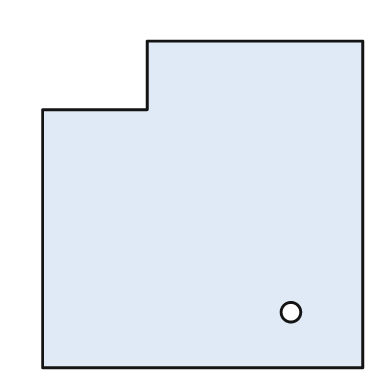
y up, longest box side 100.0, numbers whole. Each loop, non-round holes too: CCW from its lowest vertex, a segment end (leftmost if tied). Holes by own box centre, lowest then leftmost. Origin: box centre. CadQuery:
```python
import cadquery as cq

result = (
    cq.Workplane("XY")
    .moveTo(-49.0, -50.0)
    .lineTo(49.0, -50.0)
    .lineTo(49.0, 50.0)
    .lineTo(-17.0, 50.0)
    .lineTo(-17.0, 29.0)
    .lineTo(-49.0, 29.0)
    .close()
    .moveTo(27.0, -33.0)
    .circle(3.0)
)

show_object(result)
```